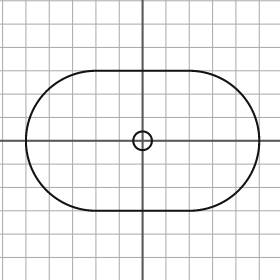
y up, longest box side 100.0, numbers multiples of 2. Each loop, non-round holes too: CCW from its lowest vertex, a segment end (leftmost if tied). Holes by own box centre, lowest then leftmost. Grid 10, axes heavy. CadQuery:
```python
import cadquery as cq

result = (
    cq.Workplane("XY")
    .moveTo(-20.0, -30.0)
    .lineTo(20.0, -30.0)
    .threePointArc((50.0, 0.0), (20.0, 30.0))
    .lineTo(-20.0, 30.0)
    .threePointArc((-50.0, 0.0), (-20.0, -30.0))
    .close()
    .moveTo(0.0, 0.0)
    .circle(4.0)
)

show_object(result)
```